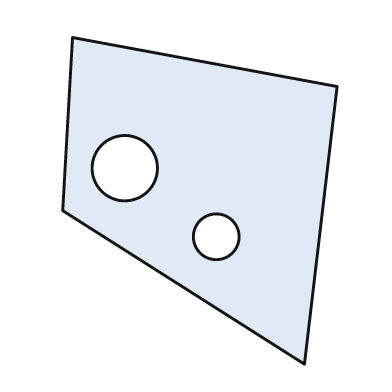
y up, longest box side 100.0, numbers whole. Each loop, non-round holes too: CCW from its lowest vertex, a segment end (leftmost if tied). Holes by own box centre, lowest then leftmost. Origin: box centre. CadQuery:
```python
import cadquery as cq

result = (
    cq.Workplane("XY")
    .moveTo(32.0, -50.0)
    .lineTo(42.0, 35.0)
    .lineTo(-39.0, 50.0)
    .lineTo(-42.0, -3.0)
    .close()
    .moveTo(5.0, -11.0)
    .circle(7.0)
    .moveTo(-23.0, 10.0)
    .circle(10.0)
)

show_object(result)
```